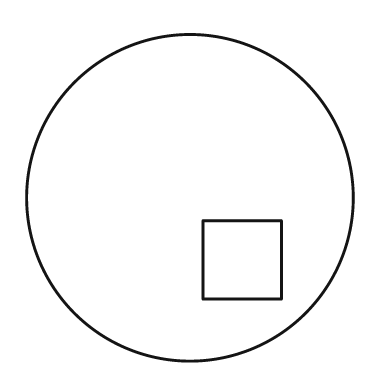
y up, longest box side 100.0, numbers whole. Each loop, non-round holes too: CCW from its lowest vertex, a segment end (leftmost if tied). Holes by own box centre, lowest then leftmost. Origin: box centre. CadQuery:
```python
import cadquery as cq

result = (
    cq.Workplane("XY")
    .moveTo(0.0, 0.0)
    .circle(50.0)
    .moveTo(4.0, -31.0)
    .lineTo(28.0, -31.0)
    .lineTo(28.0, -7.0)
    .lineTo(4.0, -7.0)
    .close()
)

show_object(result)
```